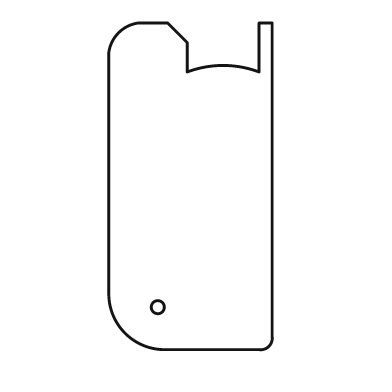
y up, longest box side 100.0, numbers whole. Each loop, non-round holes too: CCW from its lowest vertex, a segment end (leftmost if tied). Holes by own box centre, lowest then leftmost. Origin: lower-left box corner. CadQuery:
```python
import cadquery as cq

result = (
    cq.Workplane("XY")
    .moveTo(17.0, 0.0)
    .lineTo(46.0, 0.0)
    .threePointArc((49.0, 1.0), (50.0, 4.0))
    .lineTo(50.0, 100.0)
    .lineTo(46.0, 100.0)
    .lineTo(46.0, 85.0)
    .threePointArc((35.0, 87.0), (24.0, 85.0))
    .lineTo(24.0, 94.0)
    .lineTo(18.0, 100.0)
    .lineTo(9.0, 100.0)
    .threePointArc((3.0, 97.0), (0.0, 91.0))
    .lineTo(0.0, 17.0)
    .threePointArc((5.0, 5.0), (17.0, 0.0))
    .close()
    .moveTo(15.0, 13.0)
    .circle(2.0)
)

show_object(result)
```